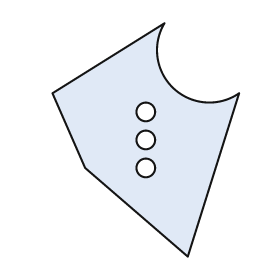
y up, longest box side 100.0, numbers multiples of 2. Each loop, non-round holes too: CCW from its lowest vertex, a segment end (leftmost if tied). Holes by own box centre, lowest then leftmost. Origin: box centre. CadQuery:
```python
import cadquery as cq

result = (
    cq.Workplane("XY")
    .moveTo(18.0, -50.0)
    .lineTo(40.0, 20.0)
    .threePointArc((12.0, 22.0), (8.0, 50.0))
    .lineTo(-40.0, 20.0)
    .lineTo(-26.0, -12.0)
    .close()
    .moveTo(0.0, -12.0)
    .circle(4.0)
    .moveTo(0.0, 0.0)
    .circle(4.0)
    .moveTo(0.0, 12.0)
    .circle(4.0)
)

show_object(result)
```